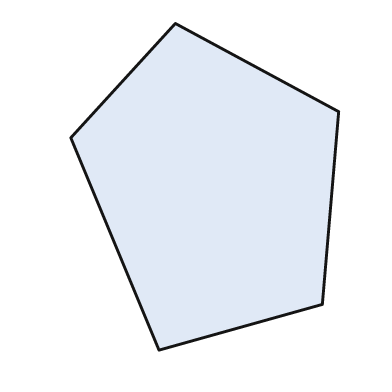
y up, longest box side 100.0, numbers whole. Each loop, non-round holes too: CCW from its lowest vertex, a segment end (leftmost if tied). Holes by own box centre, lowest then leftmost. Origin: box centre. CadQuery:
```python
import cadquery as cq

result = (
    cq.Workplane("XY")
    .moveTo(-14.0, -50.0)
    .lineTo(36.0, -36.0)
    .lineTo(41.0, 23.0)
    .lineTo(-9.0, 50.0)
    .lineTo(-41.0, 15.0)
    .close()
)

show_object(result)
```